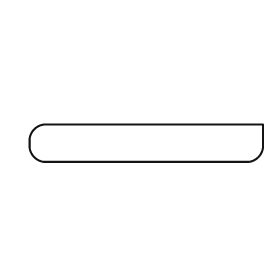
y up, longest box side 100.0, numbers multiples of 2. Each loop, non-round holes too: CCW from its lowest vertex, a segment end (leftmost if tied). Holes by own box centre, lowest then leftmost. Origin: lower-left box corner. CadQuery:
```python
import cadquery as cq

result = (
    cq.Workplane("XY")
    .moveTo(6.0, 0.0)
    .lineTo(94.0, 0.0)
    .threePointArc((98.0, 2.0), (100.0, 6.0))
    .lineTo(100.0, 16.0)
    .lineTo(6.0, 16.0)
    .threePointArc((2.0, 14.0), (0.0, 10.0))
    .lineTo(0.0, 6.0)
    .threePointArc((2.0, 2.0), (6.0, 0.0))
    .close()
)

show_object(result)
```